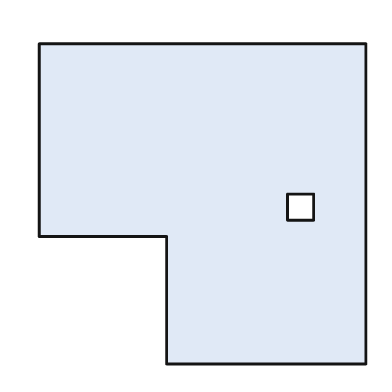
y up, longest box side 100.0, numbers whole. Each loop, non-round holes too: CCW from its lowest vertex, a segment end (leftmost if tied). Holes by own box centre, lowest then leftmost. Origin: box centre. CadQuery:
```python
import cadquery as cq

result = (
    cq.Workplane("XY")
    .moveTo(-11.0, -49.0)
    .lineTo(50.0, -49.0)
    .lineTo(50.0, 49.0)
    .lineTo(-50.0, 49.0)
    .lineTo(-50.0, -10.0)
    .lineTo(-11.0, -10.0)
    .close()
    .moveTo(26.0, -5.0)
    .lineTo(34.0, -5.0)
    .lineTo(34.0, 3.0)
    .lineTo(26.0, 3.0)
    .close()
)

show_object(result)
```